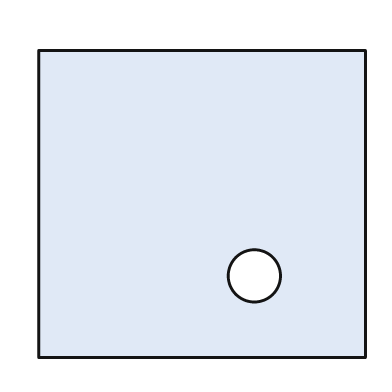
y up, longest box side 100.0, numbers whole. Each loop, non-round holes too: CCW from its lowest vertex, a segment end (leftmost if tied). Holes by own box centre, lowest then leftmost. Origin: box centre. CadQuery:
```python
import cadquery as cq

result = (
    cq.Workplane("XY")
    .moveTo(-50.0, -47.0)
    .lineTo(50.0, -47.0)
    .lineTo(50.0, 47.0)
    .lineTo(-50.0, 47.0)
    .close()
    .moveTo(16.0, -22.0)
    .circle(8.0)
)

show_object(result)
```